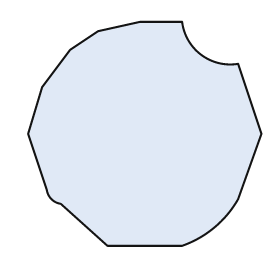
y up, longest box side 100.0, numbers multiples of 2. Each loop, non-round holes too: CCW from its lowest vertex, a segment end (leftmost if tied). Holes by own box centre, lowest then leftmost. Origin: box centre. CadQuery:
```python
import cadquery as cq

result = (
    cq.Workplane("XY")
    .moveTo(-16.0, -48.0)
    .lineTo(16.0, -48.0)
    .threePointArc((30.0, -40.0), (40.0, -28.0))
    .lineTo(50.0, 0.0)
    .lineTo(40.0, 30.0)
    .threePointArc((24.0, 34.0), (16.0, 48.0))
    .lineTo(-2.0, 48.0)
    .lineTo(-20.0, 44.0)
    .lineTo(-32.0, 36.0)
    .lineTo(-44.0, 20.0)
    .lineTo(-50.0, 0.0)
    .lineTo(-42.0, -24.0)
    .threePointArc((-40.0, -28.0), (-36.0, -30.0))
    .close()
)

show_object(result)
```